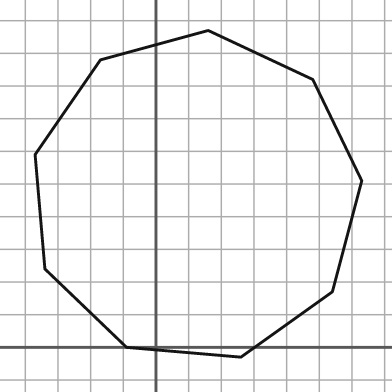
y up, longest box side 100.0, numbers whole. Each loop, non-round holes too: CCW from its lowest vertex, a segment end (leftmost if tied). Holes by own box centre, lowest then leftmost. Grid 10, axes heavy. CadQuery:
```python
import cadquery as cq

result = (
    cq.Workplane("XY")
    .moveTo(26.0, -3.0)
    .lineTo(54.0, 17.0)
    .lineTo(63.0, 51.0)
    .lineTo(48.0, 82.0)
    .lineTo(16.0, 97.0)
    .lineTo(-17.0, 88.0)
    .lineTo(-37.0, 59.0)
    .lineTo(-34.0, 24.0)
    .lineTo(-9.0, 0.0)
    .close()
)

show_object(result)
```